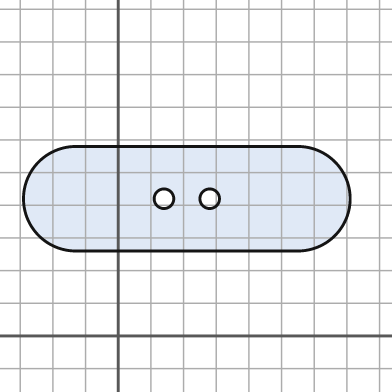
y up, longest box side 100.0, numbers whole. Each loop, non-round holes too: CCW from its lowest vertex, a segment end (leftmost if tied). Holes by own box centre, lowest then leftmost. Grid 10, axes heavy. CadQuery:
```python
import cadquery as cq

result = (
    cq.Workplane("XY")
    .moveTo(-13.0, 26.0)
    .lineTo(55.0, 26.0)
    .threePointArc((71.0, 42.0), (55.0, 58.0))
    .lineTo(-13.0, 58.0)
    .threePointArc((-29.0, 42.0), (-13.0, 26.0))
    .close()
    .moveTo(14.0, 42.0)
    .circle(3.0)
    .moveTo(28.0, 42.0)
    .circle(3.0)
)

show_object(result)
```